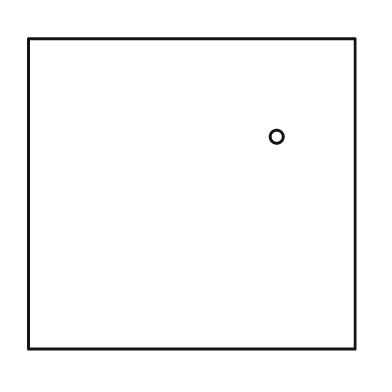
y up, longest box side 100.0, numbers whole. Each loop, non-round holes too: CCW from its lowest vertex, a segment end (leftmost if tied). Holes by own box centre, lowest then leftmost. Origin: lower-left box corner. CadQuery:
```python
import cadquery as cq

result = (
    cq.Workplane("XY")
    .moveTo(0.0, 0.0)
    .lineTo(100.0, 0.0)
    .lineTo(100.0, 95.0)
    .lineTo(0.0, 95.0)
    .close()
    .moveTo(76.0, 65.0)
    .circle(2.0)
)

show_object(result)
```